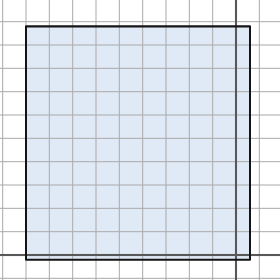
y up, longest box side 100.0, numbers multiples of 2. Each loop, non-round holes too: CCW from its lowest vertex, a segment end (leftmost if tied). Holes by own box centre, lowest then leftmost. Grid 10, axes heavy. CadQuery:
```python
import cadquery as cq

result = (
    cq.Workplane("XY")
    .moveTo(-90.0, -2.0)
    .lineTo(6.0, -2.0)
    .lineTo(6.0, 98.0)
    .lineTo(-90.0, 98.0)
    .close()
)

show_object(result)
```